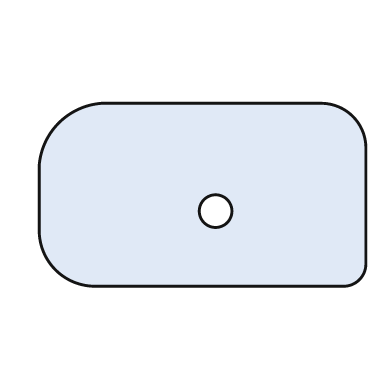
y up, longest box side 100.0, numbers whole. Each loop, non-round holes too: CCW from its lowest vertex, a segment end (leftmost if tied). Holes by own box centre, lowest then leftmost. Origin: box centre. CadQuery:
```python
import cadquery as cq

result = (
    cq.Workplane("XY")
    .moveTo(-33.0, -28.0)
    .lineTo(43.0, -28.0)
    .threePointArc((48.0, -26.0), (50.0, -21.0))
    .lineTo(50.0, 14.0)
    .threePointArc((46.0, 24.0), (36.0, 28.0))
    .lineTo(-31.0, 28.0)
    .threePointArc((-44.0, 22.0), (-50.0, 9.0))
    .lineTo(-50.0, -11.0)
    .threePointArc((-45.0, -23.0), (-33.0, -28.0))
    .close()
    .moveTo(4.0, -5.0)
    .circle(5.0)
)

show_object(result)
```